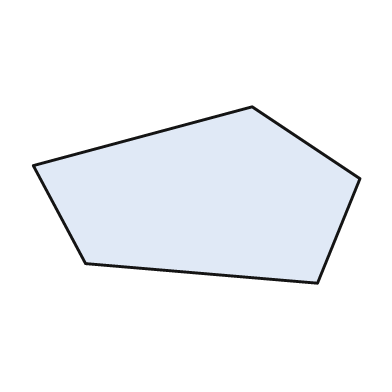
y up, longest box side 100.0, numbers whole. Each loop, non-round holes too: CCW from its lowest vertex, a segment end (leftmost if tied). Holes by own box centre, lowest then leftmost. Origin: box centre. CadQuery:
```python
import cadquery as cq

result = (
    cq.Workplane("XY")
    .moveTo(37.0, -27.0)
    .lineTo(50.0, 5.0)
    .lineTo(17.0, 27.0)
    .lineTo(-50.0, 9.0)
    .lineTo(-34.0, -21.0)
    .close()
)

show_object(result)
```